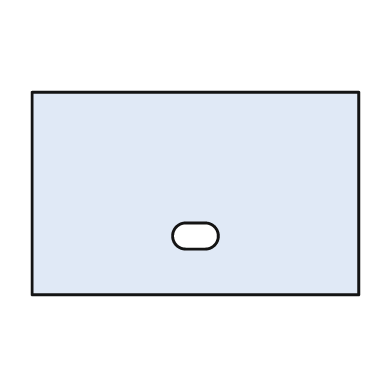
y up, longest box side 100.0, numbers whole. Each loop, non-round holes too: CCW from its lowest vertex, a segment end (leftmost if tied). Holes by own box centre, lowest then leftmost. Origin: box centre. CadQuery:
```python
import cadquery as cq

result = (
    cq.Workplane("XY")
    .moveTo(-50.0, -31.0)
    .lineTo(50.0, -31.0)
    .lineTo(50.0, 31.0)
    .lineTo(-50.0, 31.0)
    .close()
    .moveTo(-3.0, -17.0)
    .lineTo(3.0, -17.0)
    .threePointArc((7.0, -13.0), (3.0, -9.0))
    .lineTo(-3.0, -9.0)
    .threePointArc((-7.0, -13.0), (-3.0, -17.0))
    .close()
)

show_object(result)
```